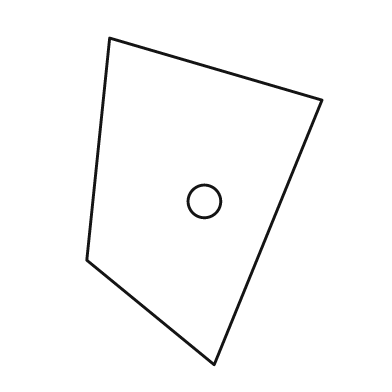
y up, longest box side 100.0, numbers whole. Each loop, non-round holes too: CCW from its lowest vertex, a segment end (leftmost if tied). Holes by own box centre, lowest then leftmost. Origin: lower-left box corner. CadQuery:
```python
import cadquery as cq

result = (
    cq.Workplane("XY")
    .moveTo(39.0, 0.0)
    .lineTo(72.0, 81.0)
    .lineTo(7.0, 100.0)
    .lineTo(0.0, 32.0)
    .close()
    .moveTo(36.0, 50.0)
    .circle(5.0)
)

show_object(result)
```